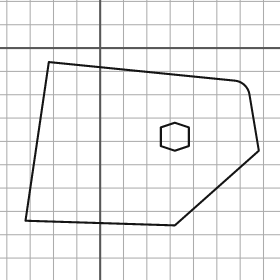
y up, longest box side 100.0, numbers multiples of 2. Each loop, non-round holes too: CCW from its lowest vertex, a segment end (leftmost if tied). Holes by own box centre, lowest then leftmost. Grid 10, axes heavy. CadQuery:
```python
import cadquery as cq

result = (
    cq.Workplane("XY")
    .moveTo(32.0, -76.0)
    .lineTo(68.0, -44.0)
    .lineTo(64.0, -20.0)
    .threePointArc((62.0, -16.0), (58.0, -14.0))
    .lineTo(-22.0, -6.0)
    .lineTo(-32.0, -74.0)
    .close()
    .moveTo(32.0, -44.0)
    .lineTo(38.0, -42.0)
    .lineTo(38.0, -34.0)
    .lineTo(32.0, -32.0)
    .lineTo(26.0, -34.0)
    .lineTo(26.0, -42.0)
    .close()
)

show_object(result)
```